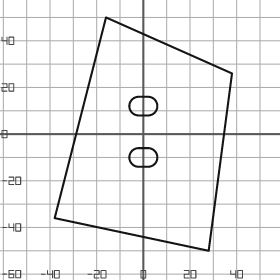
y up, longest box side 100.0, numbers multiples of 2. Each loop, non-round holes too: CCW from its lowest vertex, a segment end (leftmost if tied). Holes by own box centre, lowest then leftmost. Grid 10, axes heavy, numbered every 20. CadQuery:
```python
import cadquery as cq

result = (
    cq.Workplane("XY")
    .moveTo(28.0, -50.0)
    .lineTo(38.0, 26.0)
    .lineTo(-16.0, 50.0)
    .lineTo(-38.0, -36.0)
    .close()
    .moveTo(-2.0, -14.0)
    .lineTo(2.0, -14.0)
    .threePointArc((6.0, -10.0), (2.0, -6.0))
    .lineTo(-2.0, -6.0)
    .threePointArc((-6.0, -10.0), (-2.0, -14.0))
    .close()
    .moveTo(-2.0, 8.0)
    .lineTo(2.0, 8.0)
    .threePointArc((6.0, 12.0), (2.0, 16.0))
    .lineTo(-2.0, 16.0)
    .threePointArc((-6.0, 12.0), (-2.0, 8.0))
    .close()
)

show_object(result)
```